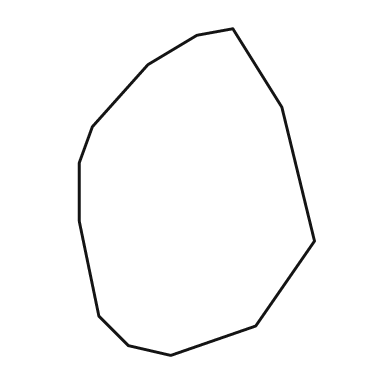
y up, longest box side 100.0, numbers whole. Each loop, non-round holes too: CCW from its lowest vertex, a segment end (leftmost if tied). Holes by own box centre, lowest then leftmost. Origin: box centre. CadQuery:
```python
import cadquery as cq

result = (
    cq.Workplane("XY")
    .moveTo(-8.0, -50.0)
    .lineTo(18.0, -41.0)
    .lineTo(36.0, -15.0)
    .lineTo(26.0, 26.0)
    .lineTo(11.0, 50.0)
    .lineTo(0.0, 48.0)
    .lineTo(-15.0, 39.0)
    .lineTo(-32.0, 20.0)
    .lineTo(-36.0, 9.0)
    .lineTo(-36.0, -9.0)
    .lineTo(-30.0, -38.0)
    .lineTo(-21.0, -47.0)
    .close()
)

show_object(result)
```